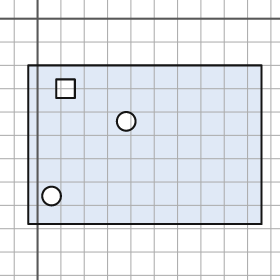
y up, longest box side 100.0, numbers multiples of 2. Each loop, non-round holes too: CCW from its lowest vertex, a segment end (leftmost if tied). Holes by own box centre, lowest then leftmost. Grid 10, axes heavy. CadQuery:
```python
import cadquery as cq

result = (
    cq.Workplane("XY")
    .moveTo(-4.0, -88.0)
    .lineTo(96.0, -88.0)
    .lineTo(96.0, -20.0)
    .lineTo(-4.0, -20.0)
    .close()
    .moveTo(6.0, -76.0)
    .circle(4.0)
    .moveTo(38.0, -44.0)
    .circle(4.0)
    .moveTo(8.0, -34.0)
    .lineTo(16.0, -34.0)
    .lineTo(16.0, -26.0)
    .lineTo(8.0, -26.0)
    .close()
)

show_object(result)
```